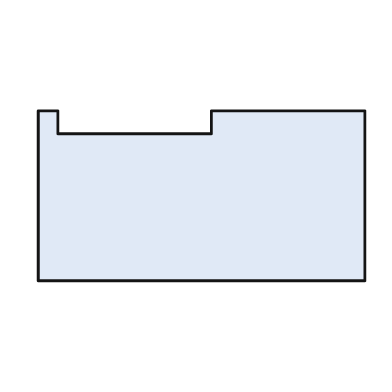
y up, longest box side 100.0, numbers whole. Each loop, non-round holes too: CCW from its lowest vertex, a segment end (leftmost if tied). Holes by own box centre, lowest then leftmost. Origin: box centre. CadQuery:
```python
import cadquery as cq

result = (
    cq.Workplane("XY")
    .moveTo(-50.0, -26.0)
    .lineTo(50.0, -26.0)
    .lineTo(50.0, 26.0)
    .lineTo(3.0, 26.0)
    .lineTo(3.0, 19.0)
    .lineTo(-44.0, 19.0)
    .lineTo(-44.0, 26.0)
    .lineTo(-50.0, 26.0)
    .close()
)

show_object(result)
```